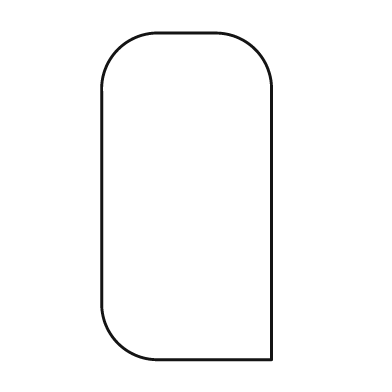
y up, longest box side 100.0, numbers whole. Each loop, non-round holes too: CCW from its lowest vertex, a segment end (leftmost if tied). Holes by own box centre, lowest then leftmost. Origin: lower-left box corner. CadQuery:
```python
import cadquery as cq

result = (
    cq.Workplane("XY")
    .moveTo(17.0, 0.0)
    .lineTo(52.0, 0.0)
    .lineTo(52.0, 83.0)
    .threePointArc((47.0, 95.0), (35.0, 100.0))
    .lineTo(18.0, 100.0)
    .threePointArc((5.0, 95.0), (0.0, 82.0))
    .lineTo(0.0, 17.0)
    .threePointArc((5.0, 5.0), (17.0, 0.0))
    .close()
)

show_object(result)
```